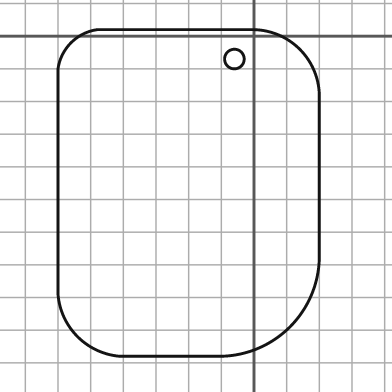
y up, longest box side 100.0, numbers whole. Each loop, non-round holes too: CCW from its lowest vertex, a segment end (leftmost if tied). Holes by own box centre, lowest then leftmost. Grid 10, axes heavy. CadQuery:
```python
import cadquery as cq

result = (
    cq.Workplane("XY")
    .moveTo(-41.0, -98.0)
    .lineTo(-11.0, -98.0)
    .threePointArc((11.0, -89.0), (20.0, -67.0))
    .lineTo(20.0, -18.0)
    .threePointArc((14.0, -4.0), (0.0, 2.0))
    .lineTo(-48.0, 2.0)
    .threePointArc((-56.0, -2.0), (-60.0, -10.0))
    .lineTo(-60.0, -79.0)
    .threePointArc((-54.0, -92.0), (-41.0, -98.0))
    .close()
    .moveTo(-6.0, -7.0)
    .circle(3.0)
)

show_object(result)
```